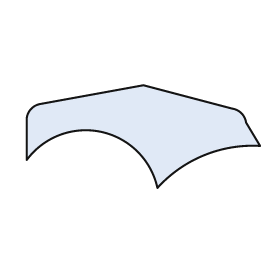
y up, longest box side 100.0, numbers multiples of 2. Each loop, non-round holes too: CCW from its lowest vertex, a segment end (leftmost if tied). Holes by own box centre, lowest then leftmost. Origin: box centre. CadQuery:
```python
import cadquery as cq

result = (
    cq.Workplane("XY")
    .moveTo(6.0, -22.0)
    .threePointArc((26.0, -8.0), (50.0, -4.0))
    .lineTo(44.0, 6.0)
    .threePointArc((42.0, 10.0), (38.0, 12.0))
    .lineTo(0.0, 22.0)
    .lineTo(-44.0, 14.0)
    .threePointArc((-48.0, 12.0), (-50.0, 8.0))
    .lineTo(-50.0, -10.0)
    .threePointArc((-18.0, 2.0), (6.0, -22.0))
    .close()
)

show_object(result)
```